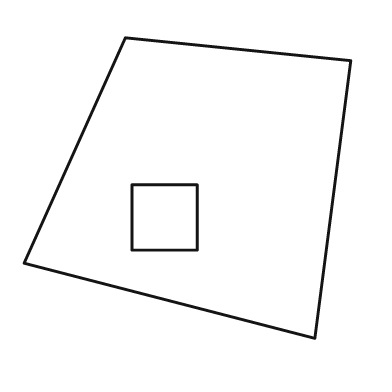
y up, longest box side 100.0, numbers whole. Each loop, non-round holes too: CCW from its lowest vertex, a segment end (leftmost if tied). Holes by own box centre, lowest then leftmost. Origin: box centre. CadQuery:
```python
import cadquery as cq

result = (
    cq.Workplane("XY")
    .moveTo(39.0, -46.0)
    .lineTo(50.0, 39.0)
    .lineTo(-19.0, 46.0)
    .lineTo(-50.0, -23.0)
    .close()
    .moveTo(-17.0, -19.0)
    .lineTo(3.0, -19.0)
    .lineTo(3.0, 1.0)
    .lineTo(-17.0, 1.0)
    .close()
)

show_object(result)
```